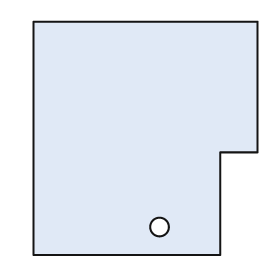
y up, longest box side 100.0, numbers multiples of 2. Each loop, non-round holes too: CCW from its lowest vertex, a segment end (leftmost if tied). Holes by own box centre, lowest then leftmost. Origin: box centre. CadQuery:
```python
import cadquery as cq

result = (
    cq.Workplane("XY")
    .moveTo(-48.0, -50.0)
    .lineTo(32.0, -50.0)
    .lineTo(32.0, -6.0)
    .lineTo(48.0, -6.0)
    .lineTo(48.0, 50.0)
    .lineTo(-48.0, 50.0)
    .close()
    .moveTo(6.0, -38.0)
    .circle(4.0)
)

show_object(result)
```